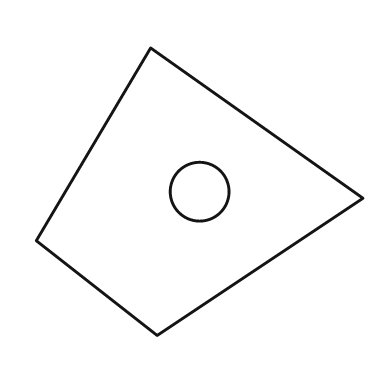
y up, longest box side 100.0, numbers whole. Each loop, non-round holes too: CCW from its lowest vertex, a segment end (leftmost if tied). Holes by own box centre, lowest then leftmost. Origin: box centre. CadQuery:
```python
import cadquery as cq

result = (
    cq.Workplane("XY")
    .moveTo(-13.0, -44.0)
    .lineTo(50.0, -2.0)
    .lineTo(-15.0, 44.0)
    .lineTo(-50.0, -15.0)
    .close()
    .moveTo(0.0, 0.0)
    .circle(9.0)
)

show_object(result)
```